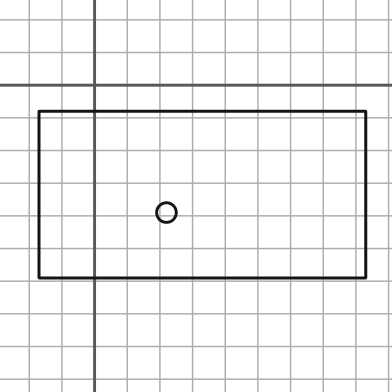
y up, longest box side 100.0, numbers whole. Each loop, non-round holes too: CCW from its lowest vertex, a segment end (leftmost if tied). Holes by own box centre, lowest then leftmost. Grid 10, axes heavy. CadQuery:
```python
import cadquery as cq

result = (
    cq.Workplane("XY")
    .moveTo(-17.0, -59.0)
    .lineTo(83.0, -59.0)
    .lineTo(83.0, -8.0)
    .lineTo(-17.0, -8.0)
    .close()
    .moveTo(22.0, -39.0)
    .circle(3.0)
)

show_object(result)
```